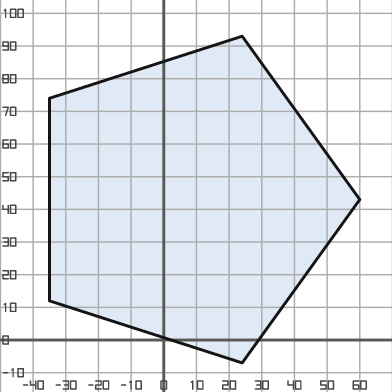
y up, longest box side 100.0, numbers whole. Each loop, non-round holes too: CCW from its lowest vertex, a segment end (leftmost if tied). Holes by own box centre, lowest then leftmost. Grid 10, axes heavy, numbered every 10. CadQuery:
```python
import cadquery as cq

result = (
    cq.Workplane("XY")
    .moveTo(24.0, -7.0)
    .lineTo(60.0, 43.0)
    .lineTo(24.0, 93.0)
    .lineTo(-35.0, 74.0)
    .lineTo(-35.0, 12.0)
    .close()
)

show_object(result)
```